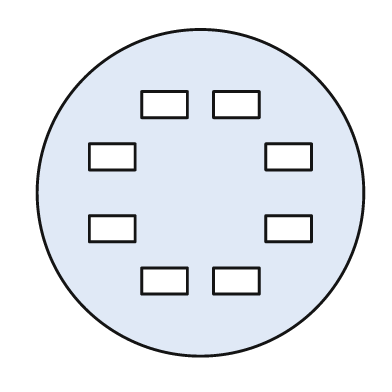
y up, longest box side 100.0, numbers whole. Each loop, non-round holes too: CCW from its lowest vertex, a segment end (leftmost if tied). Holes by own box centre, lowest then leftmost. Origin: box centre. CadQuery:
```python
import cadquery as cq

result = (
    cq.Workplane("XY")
    .moveTo(0.0, 0.0)
    .circle(50.0)
    .moveTo(-18.0, -31.0)
    .lineTo(-4.0, -31.0)
    .lineTo(-4.0, -23.0)
    .lineTo(-18.0, -23.0)
    .close()
    .moveTo(4.0, -31.0)
    .lineTo(18.0, -31.0)
    .lineTo(18.0, -23.0)
    .lineTo(4.0, -23.0)
    .close()
    .moveTo(-34.0, -15.0)
    .lineTo(-20.0, -15.0)
    .lineTo(-20.0, -7.0)
    .lineTo(-34.0, -7.0)
    .close()
    .moveTo(20.0, -15.0)
    .lineTo(34.0, -15.0)
    .lineTo(34.0, -7.0)
    .lineTo(20.0, -7.0)
    .close()
    .moveTo(-34.0, 7.0)
    .lineTo(-20.0, 7.0)
    .lineTo(-20.0, 15.0)
    .lineTo(-34.0, 15.0)
    .close()
    .moveTo(20.0, 7.0)
    .lineTo(34.0, 7.0)
    .lineTo(34.0, 15.0)
    .lineTo(20.0, 15.0)
    .close()
    .moveTo(-18.0, 23.0)
    .lineTo(-4.0, 23.0)
    .lineTo(-4.0, 31.0)
    .lineTo(-18.0, 31.0)
    .close()
    .moveTo(4.0, 23.0)
    .lineTo(18.0, 23.0)
    .lineTo(18.0, 31.0)
    .lineTo(4.0, 31.0)
    .close()
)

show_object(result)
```